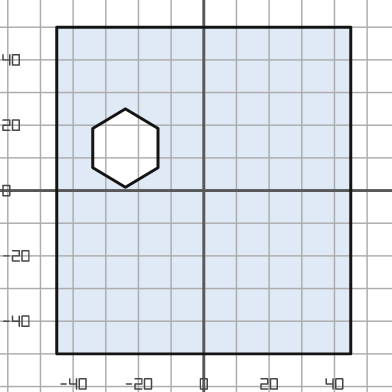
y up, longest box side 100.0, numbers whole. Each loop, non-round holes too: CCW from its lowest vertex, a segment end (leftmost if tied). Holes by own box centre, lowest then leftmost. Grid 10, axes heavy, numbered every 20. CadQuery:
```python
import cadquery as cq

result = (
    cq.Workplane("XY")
    .moveTo(-45.0, -50.0)
    .lineTo(45.0, -50.0)
    .lineTo(45.0, 50.0)
    .lineTo(-45.0, 50.0)
    .close()
    .moveTo(-24.0, 1.0)
    .lineTo(-14.0, 7.0)
    .lineTo(-14.0, 19.0)
    .lineTo(-24.0, 25.0)
    .lineTo(-34.0, 19.0)
    .lineTo(-34.0, 7.0)
    .close()
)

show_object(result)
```